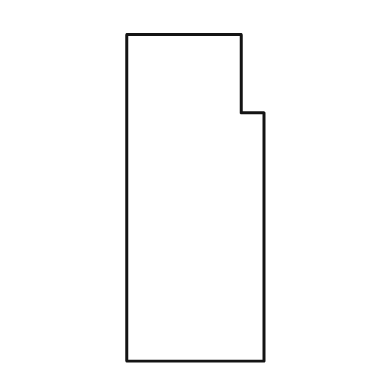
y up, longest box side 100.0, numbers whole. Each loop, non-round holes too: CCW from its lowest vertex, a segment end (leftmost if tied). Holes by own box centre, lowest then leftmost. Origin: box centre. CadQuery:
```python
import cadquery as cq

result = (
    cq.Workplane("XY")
    .moveTo(-21.0, -50.0)
    .lineTo(21.0, -50.0)
    .lineTo(21.0, 26.0)
    .lineTo(14.0, 26.0)
    .lineTo(14.0, 50.0)
    .lineTo(-21.0, 50.0)
    .close()
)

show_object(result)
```